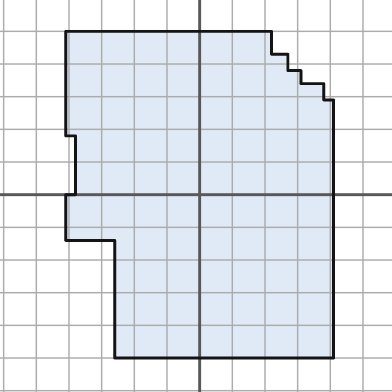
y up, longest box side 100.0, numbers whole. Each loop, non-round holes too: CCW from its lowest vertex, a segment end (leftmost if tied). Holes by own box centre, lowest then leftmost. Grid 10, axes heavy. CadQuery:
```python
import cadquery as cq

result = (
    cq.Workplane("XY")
    .moveTo(-26.0, -50.0)
    .lineTo(41.0, -50.0)
    .lineTo(41.0, 29.0)
    .lineTo(38.0, 29.0)
    .lineTo(38.0, 34.0)
    .lineTo(31.0, 34.0)
    .lineTo(31.0, 38.0)
    .lineTo(27.0, 38.0)
    .lineTo(27.0, 43.0)
    .lineTo(22.0, 43.0)
    .lineTo(22.0, 50.0)
    .lineTo(-41.0, 50.0)
    .lineTo(-41.0, 18.0)
    .lineTo(-38.0, 18.0)
    .lineTo(-38.0, 0.0)
    .lineTo(-41.0, 0.0)
    .lineTo(-41.0, -14.0)
    .lineTo(-26.0, -14.0)
    .close()
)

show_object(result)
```